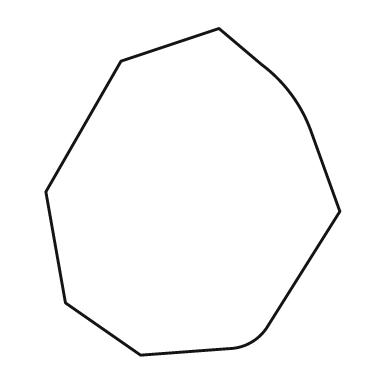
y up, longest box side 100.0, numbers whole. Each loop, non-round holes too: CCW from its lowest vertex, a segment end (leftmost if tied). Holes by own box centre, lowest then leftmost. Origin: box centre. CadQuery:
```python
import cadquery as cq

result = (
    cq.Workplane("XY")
    .moveTo(-16.0, -50.0)
    .lineTo(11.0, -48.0)
    .threePointArc((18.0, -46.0), (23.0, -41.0))
    .lineTo(45.0, -6.0)
    .lineTo(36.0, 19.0)
    .threePointArc((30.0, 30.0), (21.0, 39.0))
    .lineTo(8.0, 50.0)
    .lineTo(-22.0, 40.0)
    .lineTo(-45.0, 0.0)
    .lineTo(-39.0, -34.0)
    .close()
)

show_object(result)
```